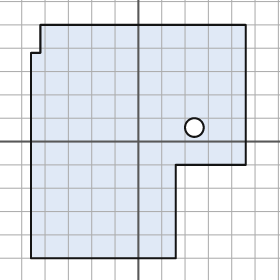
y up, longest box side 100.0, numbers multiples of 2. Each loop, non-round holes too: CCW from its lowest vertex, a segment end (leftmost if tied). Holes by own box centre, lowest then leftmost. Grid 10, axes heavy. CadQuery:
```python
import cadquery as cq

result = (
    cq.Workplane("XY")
    .moveTo(-46.0, -50.0)
    .lineTo(16.0, -50.0)
    .lineTo(16.0, -10.0)
    .lineTo(46.0, -10.0)
    .lineTo(46.0, 50.0)
    .lineTo(-42.0, 50.0)
    .lineTo(-42.0, 38.0)
    .lineTo(-46.0, 38.0)
    .close()
    .moveTo(24.0, 6.0)
    .circle(4.0)
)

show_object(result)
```